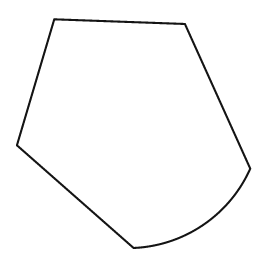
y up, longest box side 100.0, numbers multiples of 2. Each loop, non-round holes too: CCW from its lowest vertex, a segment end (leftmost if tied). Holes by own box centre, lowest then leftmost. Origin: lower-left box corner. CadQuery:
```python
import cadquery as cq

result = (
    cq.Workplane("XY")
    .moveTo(50.0, 0.0)
    .threePointArc((80.0, 10.0), (100.0, 34.0))
    .lineTo(72.0, 96.0)
    .lineTo(16.0, 98.0)
    .lineTo(0.0, 44.0)
    .close()
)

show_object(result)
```